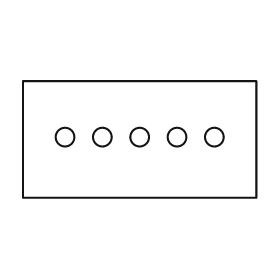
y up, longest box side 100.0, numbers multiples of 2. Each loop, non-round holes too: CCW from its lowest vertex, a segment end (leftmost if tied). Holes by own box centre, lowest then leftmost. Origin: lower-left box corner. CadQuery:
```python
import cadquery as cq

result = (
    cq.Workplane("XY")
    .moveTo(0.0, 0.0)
    .lineTo(100.0, 0.0)
    .lineTo(100.0, 50.0)
    .lineTo(0.0, 50.0)
    .close()
    .moveTo(18.0, 26.0)
    .circle(4.0)
    .moveTo(34.0, 26.0)
    .circle(4.0)
    .moveTo(50.0, 26.0)
    .circle(4.0)
    .moveTo(66.0, 26.0)
    .circle(4.0)
    .moveTo(82.0, 26.0)
    .circle(4.0)
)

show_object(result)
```